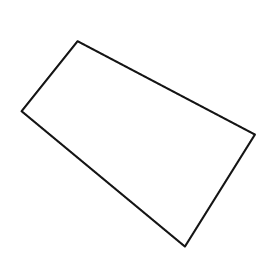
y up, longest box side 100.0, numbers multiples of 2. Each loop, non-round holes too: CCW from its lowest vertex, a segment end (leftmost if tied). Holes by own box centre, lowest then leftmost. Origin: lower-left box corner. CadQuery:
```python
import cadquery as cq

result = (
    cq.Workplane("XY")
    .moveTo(70.0, 0.0)
    .lineTo(100.0, 48.0)
    .lineTo(24.0, 88.0)
    .lineTo(0.0, 58.0)
    .close()
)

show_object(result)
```